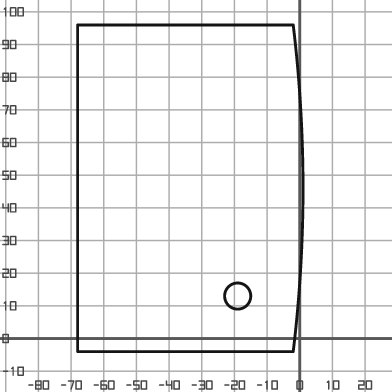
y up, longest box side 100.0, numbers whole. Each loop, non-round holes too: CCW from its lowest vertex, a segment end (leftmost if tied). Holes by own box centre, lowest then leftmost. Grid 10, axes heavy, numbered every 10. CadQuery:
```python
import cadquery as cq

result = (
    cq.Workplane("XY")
    .moveTo(-68.0, -4.0)
    .lineTo(-2.0, -4.0)
    .threePointArc((1.0, 46.0), (-2.0, 96.0))
    .lineTo(-68.0, 96.0)
    .close()
    .moveTo(-19.0, 13.0)
    .circle(4.0)
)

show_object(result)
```